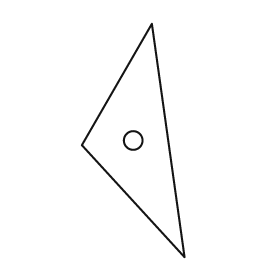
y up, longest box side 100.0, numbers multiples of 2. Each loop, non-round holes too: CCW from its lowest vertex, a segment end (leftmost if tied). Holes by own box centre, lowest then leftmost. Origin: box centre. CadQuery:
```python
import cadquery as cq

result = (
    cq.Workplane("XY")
    .moveTo(22.0, -50.0)
    .lineTo(8.0, 50.0)
    .lineTo(-22.0, -2.0)
    .close()
    .moveTo(0.0, 0.0)
    .circle(4.0)
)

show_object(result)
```